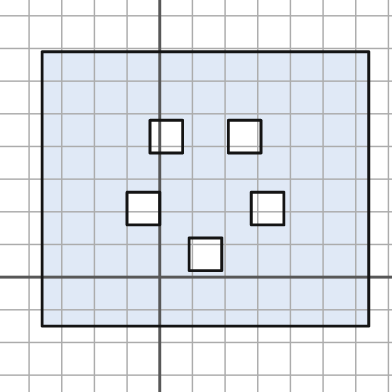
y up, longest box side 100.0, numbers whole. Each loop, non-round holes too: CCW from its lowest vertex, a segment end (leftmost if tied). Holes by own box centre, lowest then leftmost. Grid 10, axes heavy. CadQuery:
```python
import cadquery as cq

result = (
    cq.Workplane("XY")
    .moveTo(-36.0, -15.0)
    .lineTo(64.0, -15.0)
    .lineTo(64.0, 69.0)
    .lineTo(-36.0, 69.0)
    .close()
    .moveTo(9.0, 2.0)
    .lineTo(19.0, 2.0)
    .lineTo(19.0, 12.0)
    .lineTo(9.0, 12.0)
    .close()
    .moveTo(-10.0, 16.0)
    .lineTo(0.0, 16.0)
    .lineTo(0.0, 26.0)
    .lineTo(-10.0, 26.0)
    .close()
    .moveTo(28.0, 16.0)
    .lineTo(38.0, 16.0)
    .lineTo(38.0, 26.0)
    .lineTo(28.0, 26.0)
    .close()
    .moveTo(-3.0, 38.0)
    .lineTo(7.0, 38.0)
    .lineTo(7.0, 48.0)
    .lineTo(-3.0, 48.0)
    .close()
    .moveTo(21.0, 38.0)
    .lineTo(31.0, 38.0)
    .lineTo(31.0, 48.0)
    .lineTo(21.0, 48.0)
    .close()
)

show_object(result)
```